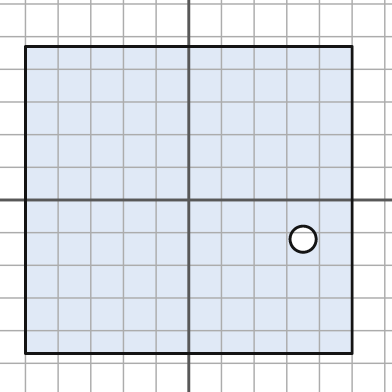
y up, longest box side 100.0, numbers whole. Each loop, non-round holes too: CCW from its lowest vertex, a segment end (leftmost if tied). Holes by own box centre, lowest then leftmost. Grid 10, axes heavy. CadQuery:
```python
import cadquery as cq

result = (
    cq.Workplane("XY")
    .moveTo(-50.0, -47.0)
    .lineTo(50.0, -47.0)
    .lineTo(50.0, 47.0)
    .lineTo(-50.0, 47.0)
    .close()
    .moveTo(35.0, -12.0)
    .circle(4.0)
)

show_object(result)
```